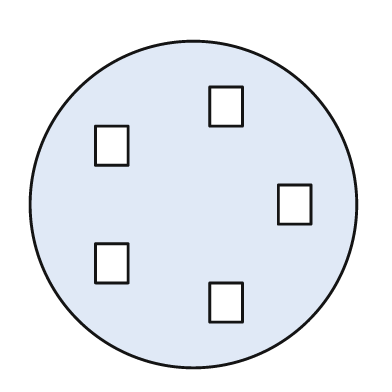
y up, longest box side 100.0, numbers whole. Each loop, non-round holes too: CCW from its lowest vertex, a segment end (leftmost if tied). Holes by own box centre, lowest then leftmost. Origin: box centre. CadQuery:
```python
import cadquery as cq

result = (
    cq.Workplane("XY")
    .moveTo(0.0, 0.0)
    .circle(50.0)
    .moveTo(5.0, -36.0)
    .lineTo(15.0, -36.0)
    .lineTo(15.0, -24.0)
    .lineTo(5.0, -24.0)
    .close()
    .moveTo(-30.0, -24.0)
    .lineTo(-20.0, -24.0)
    .lineTo(-20.0, -12.0)
    .lineTo(-30.0, -12.0)
    .close()
    .moveTo(26.0, -6.0)
    .lineTo(36.0, -6.0)
    .lineTo(36.0, 6.0)
    .lineTo(26.0, 6.0)
    .close()
    .moveTo(-30.0, 12.0)
    .lineTo(-20.0, 12.0)
    .lineTo(-20.0, 24.0)
    .lineTo(-30.0, 24.0)
    .close()
    .moveTo(5.0, 24.0)
    .lineTo(15.0, 24.0)
    .lineTo(15.0, 36.0)
    .lineTo(5.0, 36.0)
    .close()
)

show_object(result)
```